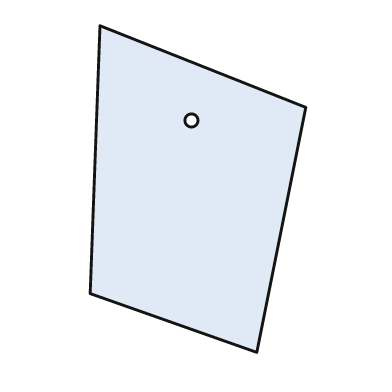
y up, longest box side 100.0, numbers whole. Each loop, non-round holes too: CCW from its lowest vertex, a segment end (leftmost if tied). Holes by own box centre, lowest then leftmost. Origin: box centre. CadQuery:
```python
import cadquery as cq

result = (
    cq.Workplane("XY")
    .moveTo(18.0, -50.0)
    .lineTo(33.0, 25.0)
    .lineTo(-30.0, 50.0)
    .lineTo(-33.0, -32.0)
    .close()
    .moveTo(-2.0, 21.0)
    .circle(2.0)
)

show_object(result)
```